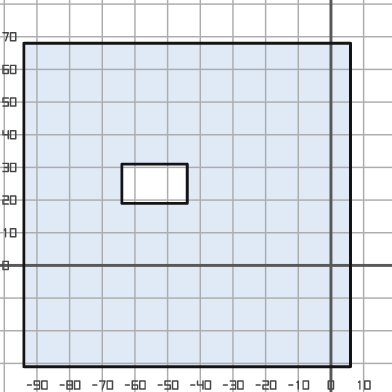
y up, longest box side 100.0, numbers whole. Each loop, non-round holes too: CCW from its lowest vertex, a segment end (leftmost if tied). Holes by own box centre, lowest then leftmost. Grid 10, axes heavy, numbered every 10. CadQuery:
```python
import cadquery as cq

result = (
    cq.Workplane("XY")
    .moveTo(-94.0, -31.0)
    .lineTo(6.0, -31.0)
    .lineTo(6.0, 68.0)
    .lineTo(-94.0, 68.0)
    .close()
    .moveTo(-64.0, 19.0)
    .lineTo(-44.0, 19.0)
    .lineTo(-44.0, 31.0)
    .lineTo(-64.0, 31.0)
    .close()
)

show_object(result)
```